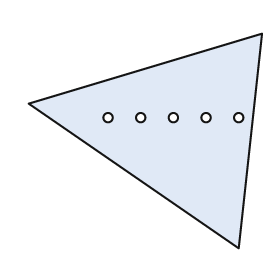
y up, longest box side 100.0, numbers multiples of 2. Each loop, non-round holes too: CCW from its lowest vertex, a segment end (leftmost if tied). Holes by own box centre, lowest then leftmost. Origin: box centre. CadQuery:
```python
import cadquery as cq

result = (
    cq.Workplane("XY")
    .moveTo(40.0, -46.0)
    .lineTo(50.0, 46.0)
    .lineTo(-50.0, 16.0)
    .close()
    .moveTo(-16.0, 10.0)
    .circle(2.0)
    .moveTo(-2.0, 10.0)
    .circle(2.0)
    .moveTo(12.0, 10.0)
    .circle(2.0)
    .moveTo(26.0, 10.0)
    .circle(2.0)
    .moveTo(40.0, 10.0)
    .circle(2.0)
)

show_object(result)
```